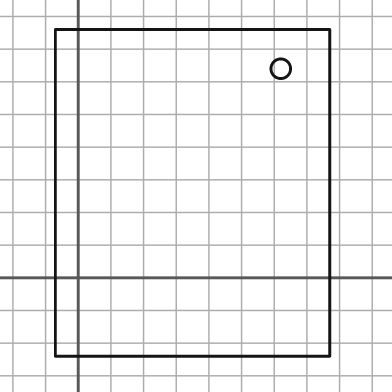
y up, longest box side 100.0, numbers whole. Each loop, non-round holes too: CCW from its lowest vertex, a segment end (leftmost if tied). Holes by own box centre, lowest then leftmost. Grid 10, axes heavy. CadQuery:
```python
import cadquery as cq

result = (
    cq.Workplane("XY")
    .moveTo(-7.0, -24.0)
    .lineTo(77.0, -24.0)
    .lineTo(77.0, 76.0)
    .lineTo(-7.0, 76.0)
    .close()
    .moveTo(62.0, 64.0)
    .circle(3.0)
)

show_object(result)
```